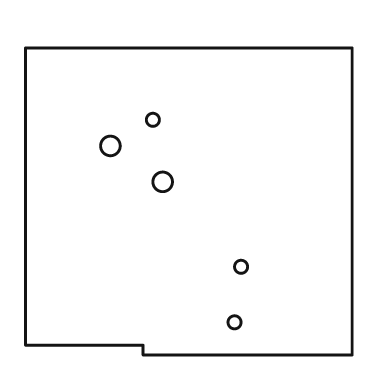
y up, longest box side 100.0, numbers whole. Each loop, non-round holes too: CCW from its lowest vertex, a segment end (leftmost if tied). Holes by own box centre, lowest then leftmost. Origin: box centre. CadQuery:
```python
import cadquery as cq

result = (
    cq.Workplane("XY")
    .moveTo(-14.0, -47.0)
    .lineTo(50.0, -47.0)
    .lineTo(50.0, 47.0)
    .lineTo(-50.0, 47.0)
    .lineTo(-50.0, -44.0)
    .lineTo(-14.0, -44.0)
    .close()
    .moveTo(14.0, -37.0)
    .circle(2.0)
    .moveTo(16.0, -20.0)
    .circle(2.0)
    .moveTo(-8.0, 6.0)
    .circle(3.0)
    .moveTo(-24.0, 17.0)
    .circle(3.0)
    .moveTo(-11.0, 25.0)
    .circle(2.0)
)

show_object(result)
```